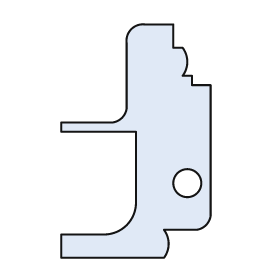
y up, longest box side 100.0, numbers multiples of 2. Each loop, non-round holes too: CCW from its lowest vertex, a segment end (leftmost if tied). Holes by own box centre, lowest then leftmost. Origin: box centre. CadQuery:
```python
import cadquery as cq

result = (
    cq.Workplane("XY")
    .moveTo(-32.0, -50.0)
    .lineTo(12.0, -50.0)
    .threePointArc((14.0, -44.0), (12.0, -38.0))
    .lineTo(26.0, -38.0)
    .threePointArc((30.0, -36.0), (32.0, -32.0))
    .lineTo(32.0, 24.0)
    .lineTo(24.0, 24.0)
    .lineTo(24.0, 28.0)
    .lineTo(20.0, 28.0)
    .threePointArc((22.0, 34.0), (20.0, 40.0))
    .lineTo(16.0, 40.0)
    .lineTo(16.0, 50.0)
    .lineTo(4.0, 50.0)
    .threePointArc((-2.0, 48.0), (-4.0, 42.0))
    .lineTo(-4.0, 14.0)
    .threePointArc((-6.0, 10.0), (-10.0, 8.0))
    .lineTo(-32.0, 8.0)
    .lineTo(-32.0, 4.0)
    .lineTo(0.0, 4.0)
    .lineTo(0.0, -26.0)
    .threePointArc((-4.0, -36.0), (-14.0, -40.0))
    .lineTo(-32.0, -40.0)
    .close()
    .moveTo(22.0, -18.0)
    .circle(6.0)
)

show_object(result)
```